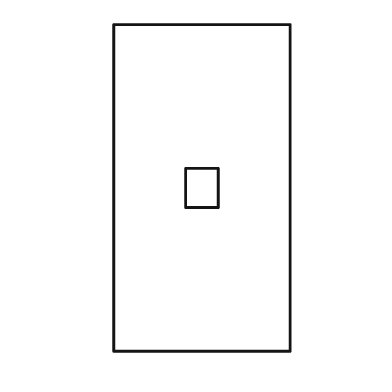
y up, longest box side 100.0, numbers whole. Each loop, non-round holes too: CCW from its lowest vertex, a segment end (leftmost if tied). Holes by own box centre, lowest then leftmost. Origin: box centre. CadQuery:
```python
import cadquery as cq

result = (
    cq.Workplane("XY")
    .moveTo(-27.0, -50.0)
    .lineTo(27.0, -50.0)
    .lineTo(27.0, 50.0)
    .lineTo(-27.0, 50.0)
    .close()
    .moveTo(-5.0, -6.0)
    .lineTo(5.0, -6.0)
    .lineTo(5.0, 6.0)
    .lineTo(-5.0, 6.0)
    .close()
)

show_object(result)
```